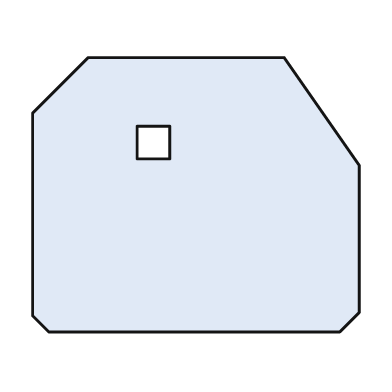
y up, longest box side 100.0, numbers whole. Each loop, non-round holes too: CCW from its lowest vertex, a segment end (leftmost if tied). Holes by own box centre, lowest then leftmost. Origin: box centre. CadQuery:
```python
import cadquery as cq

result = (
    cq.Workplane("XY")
    .moveTo(-45.0, -42.0)
    .lineTo(44.0, -42.0)
    .lineTo(50.0, -36.0)
    .lineTo(50.0, 9.0)
    .lineTo(27.0, 42.0)
    .lineTo(-33.0, 42.0)
    .lineTo(-50.0, 25.0)
    .lineTo(-50.0, -37.0)
    .close()
    .moveTo(-18.0, 11.0)
    .lineTo(-8.0, 11.0)
    .lineTo(-8.0, 21.0)
    .lineTo(-18.0, 21.0)
    .close()
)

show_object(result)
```